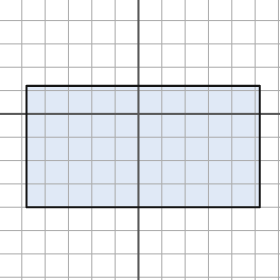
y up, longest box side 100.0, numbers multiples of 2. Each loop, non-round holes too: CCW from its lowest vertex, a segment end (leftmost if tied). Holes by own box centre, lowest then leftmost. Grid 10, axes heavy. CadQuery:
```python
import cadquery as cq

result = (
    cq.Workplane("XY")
    .moveTo(-48.0, -40.0)
    .lineTo(52.0, -40.0)
    .lineTo(52.0, 12.0)
    .lineTo(-48.0, 12.0)
    .close()
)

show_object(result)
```